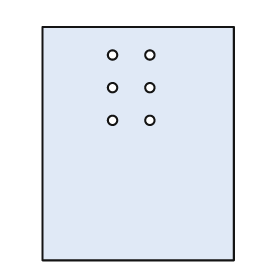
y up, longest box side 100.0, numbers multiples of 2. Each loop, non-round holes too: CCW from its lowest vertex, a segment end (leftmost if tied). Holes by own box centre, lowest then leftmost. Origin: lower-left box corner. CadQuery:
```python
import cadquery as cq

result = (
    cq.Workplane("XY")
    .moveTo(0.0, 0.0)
    .lineTo(82.0, 0.0)
    .lineTo(82.0, 100.0)
    .lineTo(0.0, 100.0)
    .close()
    .moveTo(30.0, 60.0)
    .circle(2.0)
    .moveTo(46.0, 60.0)
    .circle(2.0)
    .moveTo(30.0, 74.0)
    .circle(2.0)
    .moveTo(46.0, 74.0)
    .circle(2.0)
    .moveTo(30.0, 88.0)
    .circle(2.0)
    .moveTo(46.0, 88.0)
    .circle(2.0)
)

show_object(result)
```